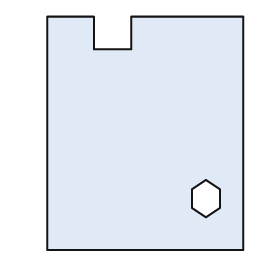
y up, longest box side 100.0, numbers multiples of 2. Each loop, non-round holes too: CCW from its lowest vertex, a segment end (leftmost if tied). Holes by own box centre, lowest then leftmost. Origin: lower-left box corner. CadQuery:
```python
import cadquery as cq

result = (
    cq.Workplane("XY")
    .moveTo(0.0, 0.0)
    .lineTo(84.0, 0.0)
    .lineTo(84.0, 100.0)
    .lineTo(36.0, 100.0)
    .lineTo(36.0, 86.0)
    .lineTo(20.0, 86.0)
    .lineTo(20.0, 100.0)
    .lineTo(0.0, 100.0)
    .close()
    .moveTo(68.0, 14.0)
    .lineTo(74.0, 18.0)
    .lineTo(74.0, 26.0)
    .lineTo(68.0, 30.0)
    .lineTo(62.0, 26.0)
    .lineTo(62.0, 18.0)
    .close()
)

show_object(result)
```